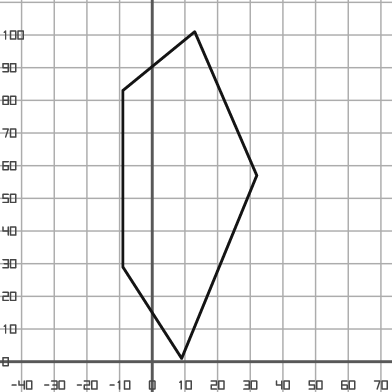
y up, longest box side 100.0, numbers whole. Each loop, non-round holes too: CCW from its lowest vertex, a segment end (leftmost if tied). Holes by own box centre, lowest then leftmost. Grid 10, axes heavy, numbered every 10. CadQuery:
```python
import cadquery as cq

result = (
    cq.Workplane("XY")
    .moveTo(9.0, 1.0)
    .lineTo(32.0, 57.0)
    .lineTo(13.0, 101.0)
    .lineTo(-9.0, 83.0)
    .lineTo(-9.0, 29.0)
    .close()
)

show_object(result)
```